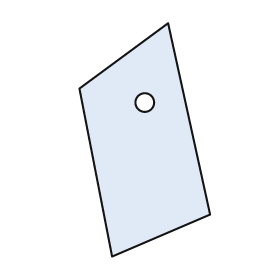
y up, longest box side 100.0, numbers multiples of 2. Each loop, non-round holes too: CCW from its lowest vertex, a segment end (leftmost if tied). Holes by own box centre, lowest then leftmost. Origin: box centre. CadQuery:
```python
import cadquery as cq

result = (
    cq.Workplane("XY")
    .moveTo(-14.0, -50.0)
    .lineTo(28.0, -32.0)
    .lineTo(10.0, 50.0)
    .lineTo(-28.0, 22.0)
    .close()
    .moveTo(0.0, 16.0)
    .circle(4.0)
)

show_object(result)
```